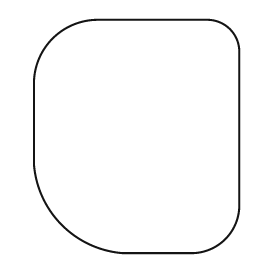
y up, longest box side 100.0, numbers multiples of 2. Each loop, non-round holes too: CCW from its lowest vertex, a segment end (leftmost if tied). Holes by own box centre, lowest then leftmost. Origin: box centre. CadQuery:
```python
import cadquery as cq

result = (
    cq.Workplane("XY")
    .moveTo(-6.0, -50.0)
    .lineTo(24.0, -50.0)
    .threePointArc((38.0, -44.0), (44.0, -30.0))
    .lineTo(44.0, 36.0)
    .threePointArc((40.0, 46.0), (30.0, 50.0))
    .lineTo(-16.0, 50.0)
    .threePointArc((-36.0, 42.0), (-44.0, 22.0))
    .lineTo(-44.0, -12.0)
    .threePointArc((-32.0, -38.0), (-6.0, -50.0))
    .close()
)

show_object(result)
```